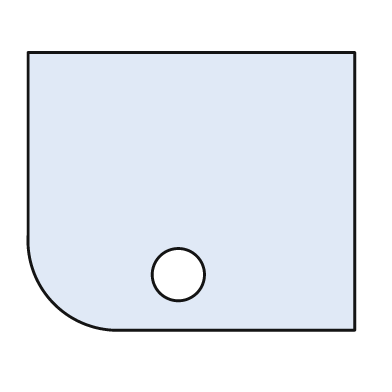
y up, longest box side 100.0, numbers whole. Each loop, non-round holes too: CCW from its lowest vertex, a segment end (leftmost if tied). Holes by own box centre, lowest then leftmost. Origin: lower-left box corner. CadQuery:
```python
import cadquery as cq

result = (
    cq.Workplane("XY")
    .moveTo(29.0, 0.0)
    .lineTo(100.0, 0.0)
    .lineTo(100.0, 85.0)
    .lineTo(0.0, 85.0)
    .lineTo(0.0, 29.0)
    .threePointArc((8.0, 8.0), (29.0, 0.0))
    .close()
    .moveTo(46.0, 17.0)
    .circle(8.0)
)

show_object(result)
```